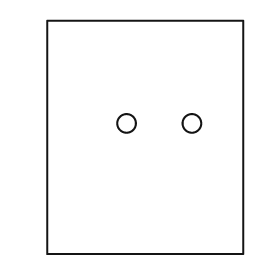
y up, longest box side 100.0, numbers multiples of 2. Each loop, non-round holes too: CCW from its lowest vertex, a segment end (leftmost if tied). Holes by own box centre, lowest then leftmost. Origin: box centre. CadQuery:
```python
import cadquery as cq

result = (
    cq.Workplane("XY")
    .moveTo(-42.0, -50.0)
    .lineTo(42.0, -50.0)
    .lineTo(42.0, 50.0)
    .lineTo(-42.0, 50.0)
    .close()
    .moveTo(-8.0, 6.0)
    .circle(4.0)
    .moveTo(20.0, 6.0)
    .circle(4.0)
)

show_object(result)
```